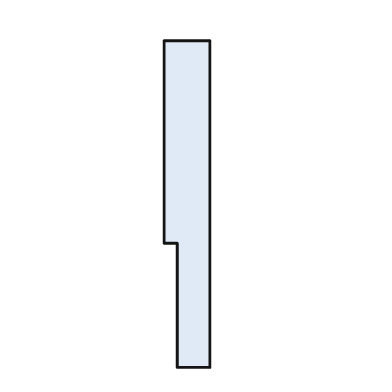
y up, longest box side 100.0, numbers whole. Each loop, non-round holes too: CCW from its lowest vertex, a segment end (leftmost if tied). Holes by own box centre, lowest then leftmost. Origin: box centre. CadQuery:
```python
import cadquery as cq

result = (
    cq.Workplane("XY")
    .moveTo(-3.0, -50.0)
    .lineTo(7.0, -50.0)
    .lineTo(7.0, 50.0)
    .lineTo(-7.0, 50.0)
    .lineTo(-7.0, -12.0)
    .lineTo(-3.0, -12.0)
    .close()
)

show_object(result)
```